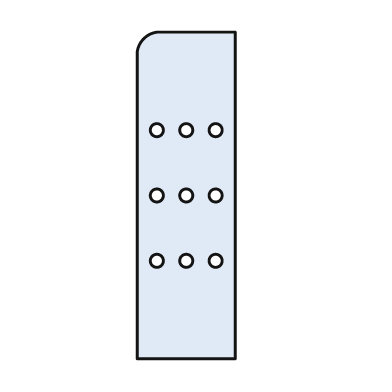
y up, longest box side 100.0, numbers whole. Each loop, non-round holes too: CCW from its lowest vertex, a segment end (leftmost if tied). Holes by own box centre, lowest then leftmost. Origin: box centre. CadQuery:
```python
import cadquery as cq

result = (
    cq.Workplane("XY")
    .moveTo(-15.0, -50.0)
    .lineTo(15.0, -50.0)
    .lineTo(15.0, 50.0)
    .lineTo(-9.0, 50.0)
    .threePointArc((-13.0, 48.0), (-15.0, 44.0))
    .close()
    .moveTo(-9.0, -20.0)
    .circle(2.0)
    .moveTo(0.0, -20.0)
    .circle(2.0)
    .moveTo(9.0, -20.0)
    .circle(2.0)
    .moveTo(-9.0, 0.0)
    .circle(2.0)
    .moveTo(0.0, 0.0)
    .circle(2.0)
    .moveTo(9.0, 0.0)
    .circle(2.0)
    .moveTo(-9.0, 20.0)
    .circle(2.0)
    .moveTo(0.0, 20.0)
    .circle(2.0)
    .moveTo(9.0, 20.0)
    .circle(2.0)
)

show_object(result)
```